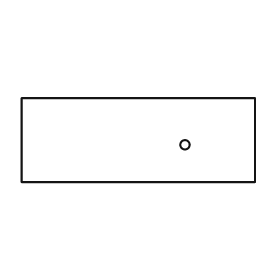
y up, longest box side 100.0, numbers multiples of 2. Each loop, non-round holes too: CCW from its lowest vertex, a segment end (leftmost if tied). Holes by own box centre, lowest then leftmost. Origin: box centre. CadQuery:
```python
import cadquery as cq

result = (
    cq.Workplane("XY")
    .moveTo(-50.0, -18.0)
    .lineTo(50.0, -18.0)
    .lineTo(50.0, 18.0)
    .lineTo(-50.0, 18.0)
    .close()
    .moveTo(20.0, -2.0)
    .circle(2.0)
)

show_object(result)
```